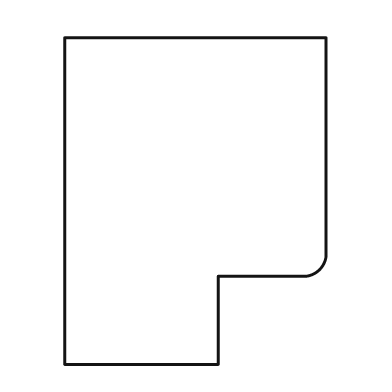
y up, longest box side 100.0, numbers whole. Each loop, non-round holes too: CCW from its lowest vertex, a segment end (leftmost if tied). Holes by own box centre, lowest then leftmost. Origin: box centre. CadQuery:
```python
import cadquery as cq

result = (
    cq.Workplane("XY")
    .moveTo(-40.0, -50.0)
    .lineTo(7.0, -50.0)
    .lineTo(7.0, -23.0)
    .lineTo(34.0, -23.0)
    .threePointArc((38.0, -21.0), (40.0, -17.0))
    .lineTo(40.0, 50.0)
    .lineTo(-40.0, 50.0)
    .close()
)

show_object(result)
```